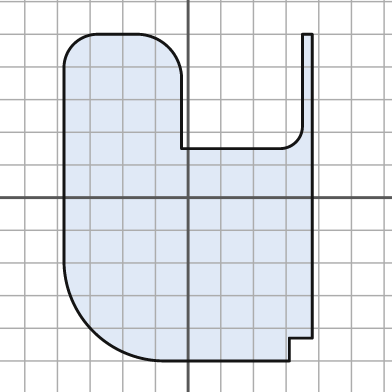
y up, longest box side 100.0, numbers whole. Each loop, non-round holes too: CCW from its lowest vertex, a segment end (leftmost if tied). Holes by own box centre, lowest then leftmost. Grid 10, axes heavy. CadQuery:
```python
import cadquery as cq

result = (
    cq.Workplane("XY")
    .moveTo(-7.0, -50.0)
    .lineTo(31.0, -50.0)
    .lineTo(31.0, -43.0)
    .lineTo(38.0, -43.0)
    .lineTo(38.0, 50.0)
    .lineTo(35.0, 50.0)
    .lineTo(35.0, 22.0)
    .threePointArc((33.0, 17.0), (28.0, 15.0))
    .lineTo(-2.0, 15.0)
    .lineTo(-2.0, 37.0)
    .threePointArc((-6.0, 46.0), (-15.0, 50.0))
    .lineTo(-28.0, 50.0)
    .threePointArc((-35.0, 47.0), (-38.0, 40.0))
    .lineTo(-38.0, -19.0)
    .threePointArc((-29.0, -41.0), (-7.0, -50.0))
    .close()
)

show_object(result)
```